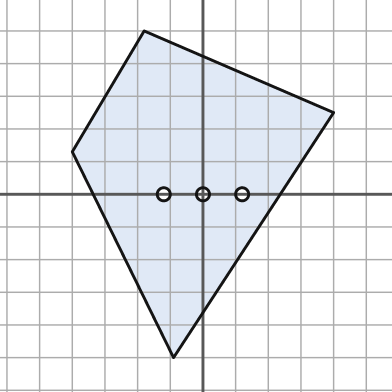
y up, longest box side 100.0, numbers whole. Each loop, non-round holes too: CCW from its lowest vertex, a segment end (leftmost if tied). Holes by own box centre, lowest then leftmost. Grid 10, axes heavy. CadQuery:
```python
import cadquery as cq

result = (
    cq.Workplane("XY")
    .moveTo(-9.0, -50.0)
    .lineTo(40.0, 25.0)
    .lineTo(-18.0, 50.0)
    .lineTo(-40.0, 13.0)
    .close()
    .moveTo(-12.0, 0.0)
    .circle(2.0)
    .moveTo(0.0, 0.0)
    .circle(2.0)
    .moveTo(12.0, 0.0)
    .circle(2.0)
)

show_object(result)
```